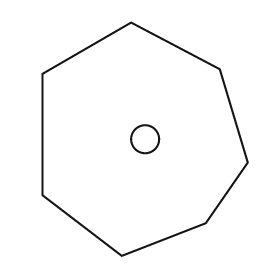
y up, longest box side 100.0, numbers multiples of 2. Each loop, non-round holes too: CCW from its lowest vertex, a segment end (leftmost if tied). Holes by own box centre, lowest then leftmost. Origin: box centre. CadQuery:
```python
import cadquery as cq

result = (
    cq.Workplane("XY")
    .moveTo(-10.0, -50.0)
    .lineTo(26.0, -36.0)
    .lineTo(44.0, -10.0)
    .lineTo(32.0, 30.0)
    .lineTo(-6.0, 50.0)
    .lineTo(-44.0, 28.0)
    .lineTo(-44.0, -24.0)
    .close()
    .moveTo(0.0, 0.0)
    .circle(6.0)
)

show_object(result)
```